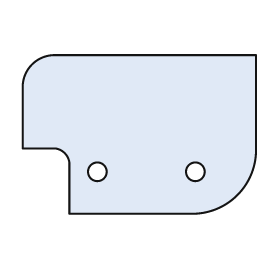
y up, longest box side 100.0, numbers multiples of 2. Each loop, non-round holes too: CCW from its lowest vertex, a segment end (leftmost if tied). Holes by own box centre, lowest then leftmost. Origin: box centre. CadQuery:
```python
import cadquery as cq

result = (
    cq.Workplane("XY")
    .moveTo(-30.0, -34.0)
    .lineTo(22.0, -34.0)
    .threePointArc((42.0, -26.0), (50.0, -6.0))
    .lineTo(50.0, 34.0)
    .lineTo(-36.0, 34.0)
    .threePointArc((-46.0, 30.0), (-50.0, 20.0))
    .lineTo(-50.0, -6.0)
    .lineTo(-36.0, -6.0)
    .threePointArc((-32.0, -8.0), (-30.0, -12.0))
    .close()
    .moveTo(-18.0, -16.0)
    .circle(4.0)
    .moveTo(24.0, -16.0)
    .circle(4.0)
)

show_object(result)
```